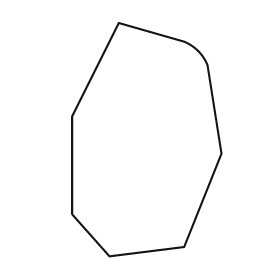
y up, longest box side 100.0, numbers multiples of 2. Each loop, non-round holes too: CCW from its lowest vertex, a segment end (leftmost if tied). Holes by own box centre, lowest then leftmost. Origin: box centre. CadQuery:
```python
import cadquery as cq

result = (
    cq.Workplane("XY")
    .moveTo(-16.0, -50.0)
    .lineTo(16.0, -46.0)
    .lineTo(32.0, -6.0)
    .lineTo(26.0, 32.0)
    .threePointArc((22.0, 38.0), (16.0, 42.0))
    .lineTo(-12.0, 50.0)
    .lineTo(-32.0, 10.0)
    .lineTo(-32.0, -32.0)
    .close()
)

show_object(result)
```